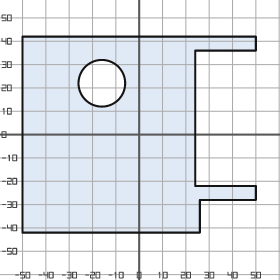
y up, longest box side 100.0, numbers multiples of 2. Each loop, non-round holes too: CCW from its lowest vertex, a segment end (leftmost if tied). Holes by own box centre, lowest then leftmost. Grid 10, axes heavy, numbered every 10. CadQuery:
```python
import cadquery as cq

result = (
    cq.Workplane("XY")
    .moveTo(-50.0, -42.0)
    .lineTo(26.0, -42.0)
    .lineTo(26.0, -28.0)
    .lineTo(50.0, -28.0)
    .lineTo(50.0, -22.0)
    .lineTo(24.0, -22.0)
    .lineTo(24.0, 36.0)
    .lineTo(50.0, 36.0)
    .lineTo(50.0, 42.0)
    .lineTo(-50.0, 42.0)
    .close()
    .moveTo(-16.0, 22.0)
    .circle(10.0)
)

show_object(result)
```